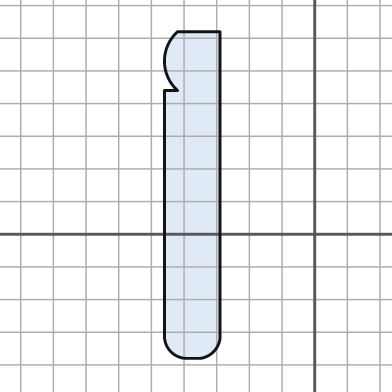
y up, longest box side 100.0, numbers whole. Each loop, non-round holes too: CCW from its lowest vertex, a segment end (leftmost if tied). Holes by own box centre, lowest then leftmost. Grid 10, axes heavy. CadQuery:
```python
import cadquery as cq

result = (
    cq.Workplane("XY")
    .moveTo(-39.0, -38.0)
    .lineTo(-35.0, -38.0)
    .threePointArc((-31.0, -36.0), (-29.0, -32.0))
    .lineTo(-29.0, 62.0)
    .lineTo(-42.0, 62.0)
    .threePointArc((-46.0, 53.0), (-42.0, 44.0))
    .lineTo(-46.0, 44.0)
    .lineTo(-46.0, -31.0)
    .threePointArc((-44.0, -36.0), (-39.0, -38.0))
    .close()
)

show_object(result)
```